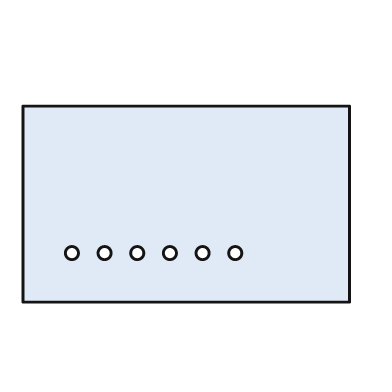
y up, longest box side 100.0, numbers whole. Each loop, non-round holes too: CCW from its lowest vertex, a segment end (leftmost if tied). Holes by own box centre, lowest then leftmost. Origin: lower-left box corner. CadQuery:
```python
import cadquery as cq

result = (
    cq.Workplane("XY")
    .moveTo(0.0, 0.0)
    .lineTo(100.0, 0.0)
    .lineTo(100.0, 60.0)
    .lineTo(0.0, 60.0)
    .close()
    .moveTo(15.0, 15.0)
    .circle(2.0)
    .moveTo(25.0, 15.0)
    .circle(2.0)
    .moveTo(35.0, 15.0)
    .circle(2.0)
    .moveTo(45.0, 15.0)
    .circle(2.0)
    .moveTo(55.0, 15.0)
    .circle(2.0)
    .moveTo(65.0, 15.0)
    .circle(2.0)
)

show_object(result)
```